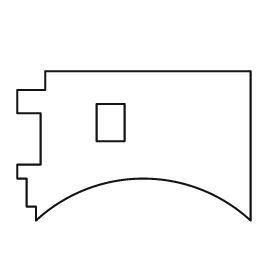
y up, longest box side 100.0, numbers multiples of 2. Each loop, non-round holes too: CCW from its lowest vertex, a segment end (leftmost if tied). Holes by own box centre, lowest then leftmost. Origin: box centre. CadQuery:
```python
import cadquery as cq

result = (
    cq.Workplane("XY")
    .moveTo(-42.0, -32.0)
    .threePointArc((4.0, -14.0), (50.0, -32.0))
    .lineTo(50.0, 32.0)
    .lineTo(-38.0, 32.0)
    .lineTo(-38.0, 24.0)
    .lineTo(-50.0, 24.0)
    .lineTo(-50.0, 14.0)
    .lineTo(-40.0, 14.0)
    .lineTo(-40.0, -8.0)
    .lineTo(-50.0, -8.0)
    .lineTo(-50.0, -14.0)
    .lineTo(-46.0, -14.0)
    .lineTo(-46.0, -26.0)
    .lineTo(-42.0, -26.0)
    .close()
    .moveTo(-16.0, 2.0)
    .lineTo(-4.0, 2.0)
    .lineTo(-4.0, 18.0)
    .lineTo(-16.0, 18.0)
    .close()
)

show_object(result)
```